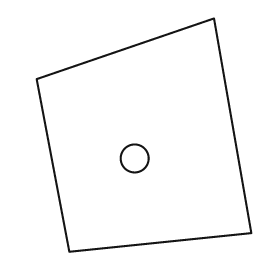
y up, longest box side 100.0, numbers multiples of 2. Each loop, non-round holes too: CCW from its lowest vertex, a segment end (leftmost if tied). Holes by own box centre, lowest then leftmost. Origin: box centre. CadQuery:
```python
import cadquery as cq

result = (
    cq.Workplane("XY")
    .moveTo(-32.0, -50.0)
    .lineTo(46.0, -42.0)
    .lineTo(30.0, 50.0)
    .lineTo(-46.0, 24.0)
    .close()
    .moveTo(-4.0, -10.0)
    .circle(6.0)
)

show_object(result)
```